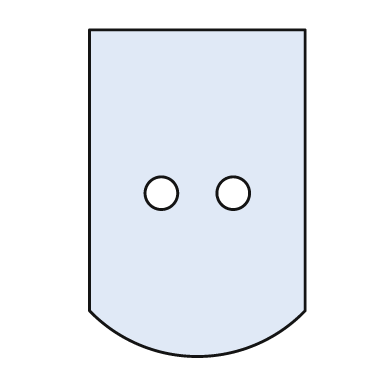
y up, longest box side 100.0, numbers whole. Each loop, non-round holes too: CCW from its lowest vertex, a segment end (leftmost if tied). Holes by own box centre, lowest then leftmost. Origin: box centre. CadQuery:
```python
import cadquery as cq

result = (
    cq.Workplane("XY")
    .moveTo(-33.0, -36.0)
    .threePointArc((0.0, -50.0), (33.0, -36.0))
    .lineTo(33.0, 50.0)
    .lineTo(-33.0, 50.0)
    .close()
    .moveTo(-11.0, 0.0)
    .circle(5.0)
    .moveTo(11.0, 0.0)
    .circle(5.0)
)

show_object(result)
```